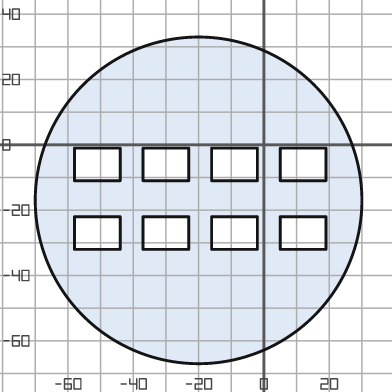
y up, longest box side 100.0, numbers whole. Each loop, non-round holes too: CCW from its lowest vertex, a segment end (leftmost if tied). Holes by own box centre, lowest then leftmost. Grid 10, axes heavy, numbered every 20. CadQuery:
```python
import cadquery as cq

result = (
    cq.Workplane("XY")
    .moveTo(-20.0, -17.0)
    .circle(50.0)
    .moveTo(-58.0, -32.0)
    .lineTo(-44.0, -32.0)
    .lineTo(-44.0, -22.0)
    .lineTo(-58.0, -22.0)
    .close()
    .moveTo(-37.0, -32.0)
    .lineTo(-23.0, -32.0)
    .lineTo(-23.0, -22.0)
    .lineTo(-37.0, -22.0)
    .close()
    .moveTo(-16.0, -32.0)
    .lineTo(-2.0, -32.0)
    .lineTo(-2.0, -22.0)
    .lineTo(-16.0, -22.0)
    .close()
    .moveTo(5.0, -32.0)
    .lineTo(19.0, -32.0)
    .lineTo(19.0, -22.0)
    .lineTo(5.0, -22.0)
    .close()
    .moveTo(-58.0, -11.0)
    .lineTo(-44.0, -11.0)
    .lineTo(-44.0, -1.0)
    .lineTo(-58.0, -1.0)
    .close()
    .moveTo(-37.0, -11.0)
    .lineTo(-23.0, -11.0)
    .lineTo(-23.0, -1.0)
    .lineTo(-37.0, -1.0)
    .close()
    .moveTo(-16.0, -11.0)
    .lineTo(-2.0, -11.0)
    .lineTo(-2.0, -1.0)
    .lineTo(-16.0, -1.0)
    .close()
    .moveTo(5.0, -11.0)
    .lineTo(19.0, -11.0)
    .lineTo(19.0, -1.0)
    .lineTo(5.0, -1.0)
    .close()
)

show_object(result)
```